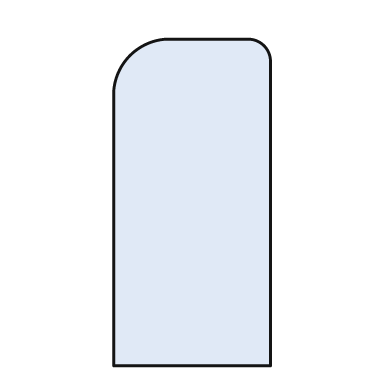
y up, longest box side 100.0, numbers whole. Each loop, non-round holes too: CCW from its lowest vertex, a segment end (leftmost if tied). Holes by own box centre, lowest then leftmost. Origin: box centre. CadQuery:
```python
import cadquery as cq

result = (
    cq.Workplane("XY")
    .moveTo(-24.0, -50.0)
    .lineTo(24.0, -50.0)
    .lineTo(24.0, 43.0)
    .threePointArc((22.0, 48.0), (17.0, 50.0))
    .lineTo(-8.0, 50.0)
    .threePointArc((-19.0, 45.0), (-24.0, 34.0))
    .close()
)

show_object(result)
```